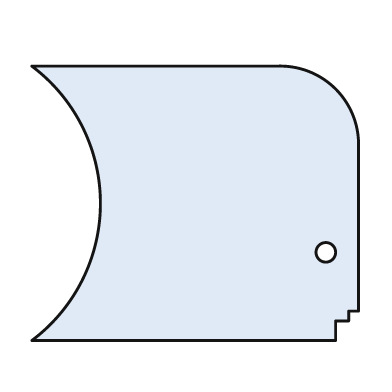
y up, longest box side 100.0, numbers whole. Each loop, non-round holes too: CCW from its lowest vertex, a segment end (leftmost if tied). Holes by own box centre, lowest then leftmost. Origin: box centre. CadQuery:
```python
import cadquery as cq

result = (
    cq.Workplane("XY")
    .moveTo(-50.0, -42.0)
    .lineTo(43.0, -42.0)
    .lineTo(43.0, -36.0)
    .lineTo(47.0, -36.0)
    .lineTo(47.0, -33.0)
    .lineTo(50.0, -33.0)
    .lineTo(50.0, 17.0)
    .threePointArc((43.0, 35.0), (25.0, 42.0))
    .lineTo(-50.0, 42.0)
    .threePointArc((-29.0, 0.0), (-50.0, -42.0))
    .close()
    .moveTo(40.0, -15.0)
    .circle(3.0)
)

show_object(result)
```